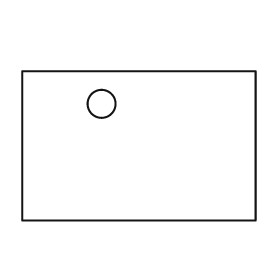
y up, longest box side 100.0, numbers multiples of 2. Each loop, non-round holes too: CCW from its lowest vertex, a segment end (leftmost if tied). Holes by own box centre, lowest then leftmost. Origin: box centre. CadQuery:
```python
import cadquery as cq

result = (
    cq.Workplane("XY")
    .moveTo(-50.0, -32.0)
    .lineTo(50.0, -32.0)
    .lineTo(50.0, 32.0)
    .lineTo(-50.0, 32.0)
    .close()
    .moveTo(-16.0, 18.0)
    .circle(6.0)
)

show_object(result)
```